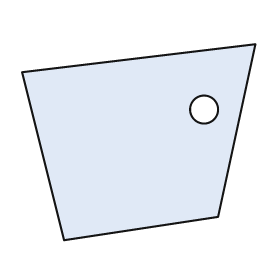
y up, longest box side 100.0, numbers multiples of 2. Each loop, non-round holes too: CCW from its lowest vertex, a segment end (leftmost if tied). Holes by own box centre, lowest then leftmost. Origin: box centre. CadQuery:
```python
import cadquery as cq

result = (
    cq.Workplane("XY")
    .moveTo(-32.0, -42.0)
    .lineTo(34.0, -32.0)
    .lineTo(50.0, 42.0)
    .lineTo(-50.0, 30.0)
    .close()
    .moveTo(28.0, 14.0)
    .circle(6.0)
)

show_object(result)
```